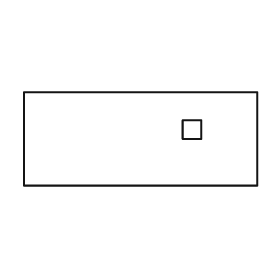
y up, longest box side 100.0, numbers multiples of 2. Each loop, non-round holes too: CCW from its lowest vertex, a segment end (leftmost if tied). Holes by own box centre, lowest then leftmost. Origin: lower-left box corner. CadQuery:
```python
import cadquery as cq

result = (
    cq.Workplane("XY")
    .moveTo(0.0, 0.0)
    .lineTo(100.0, 0.0)
    .lineTo(100.0, 40.0)
    .lineTo(0.0, 40.0)
    .close()
    .moveTo(68.0, 20.0)
    .lineTo(76.0, 20.0)
    .lineTo(76.0, 28.0)
    .lineTo(68.0, 28.0)
    .close()
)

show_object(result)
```